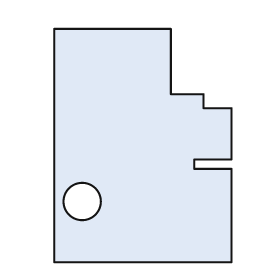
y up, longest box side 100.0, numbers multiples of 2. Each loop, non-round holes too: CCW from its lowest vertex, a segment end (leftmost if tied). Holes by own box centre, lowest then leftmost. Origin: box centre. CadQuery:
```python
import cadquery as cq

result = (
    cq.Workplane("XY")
    .moveTo(-38.0, -50.0)
    .lineTo(38.0, -50.0)
    .lineTo(38.0, -10.0)
    .lineTo(22.0, -10.0)
    .lineTo(22.0, -6.0)
    .lineTo(38.0, -6.0)
    .lineTo(38.0, 16.0)
    .lineTo(26.0, 16.0)
    .lineTo(26.0, 22.0)
    .lineTo(12.0, 22.0)
    .lineTo(12.0, 50.0)
    .lineTo(-38.0, 50.0)
    .close()
    .moveTo(-26.0, -24.0)
    .circle(8.0)
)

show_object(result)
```